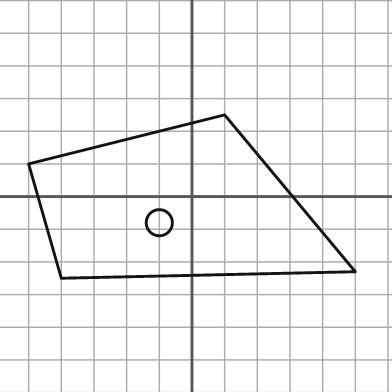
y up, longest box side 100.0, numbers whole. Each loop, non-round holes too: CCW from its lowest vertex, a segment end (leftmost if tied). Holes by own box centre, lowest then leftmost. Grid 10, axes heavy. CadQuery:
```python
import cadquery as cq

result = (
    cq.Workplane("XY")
    .moveTo(-40.0, -25.0)
    .lineTo(50.0, -23.0)
    .lineTo(10.0, 25.0)
    .lineTo(-50.0, 10.0)
    .close()
    .moveTo(-10.0, -8.0)
    .circle(4.0)
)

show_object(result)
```